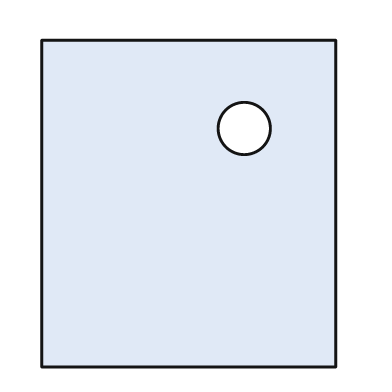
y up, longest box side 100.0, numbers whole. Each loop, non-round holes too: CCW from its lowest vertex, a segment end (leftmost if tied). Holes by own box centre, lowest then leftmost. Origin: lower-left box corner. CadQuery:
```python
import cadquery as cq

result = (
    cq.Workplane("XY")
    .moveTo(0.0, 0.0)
    .lineTo(90.0, 0.0)
    .lineTo(90.0, 100.0)
    .lineTo(0.0, 100.0)
    .close()
    .moveTo(62.0, 73.0)
    .circle(8.0)
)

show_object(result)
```